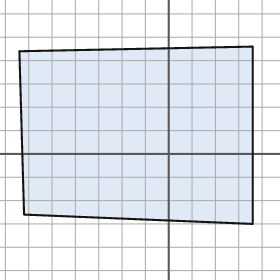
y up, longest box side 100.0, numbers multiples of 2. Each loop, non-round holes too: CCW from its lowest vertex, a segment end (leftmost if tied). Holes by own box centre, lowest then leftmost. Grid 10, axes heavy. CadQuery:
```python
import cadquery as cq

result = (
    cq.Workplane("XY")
    .moveTo(36.0, -30.0)
    .lineTo(36.0, 46.0)
    .lineTo(-64.0, 44.0)
    .lineTo(-62.0, -26.0)
    .close()
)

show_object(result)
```